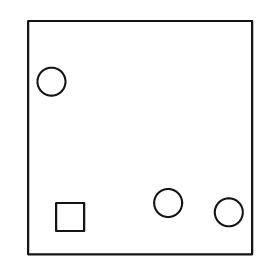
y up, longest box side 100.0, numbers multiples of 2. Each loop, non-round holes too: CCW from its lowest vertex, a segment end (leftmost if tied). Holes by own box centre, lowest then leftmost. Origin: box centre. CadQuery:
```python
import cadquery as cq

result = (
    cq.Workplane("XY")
    .moveTo(-48.0, -50.0)
    .lineTo(48.0, -50.0)
    .lineTo(48.0, 50.0)
    .lineTo(-48.0, 50.0)
    .close()
    .moveTo(-36.0, -40.0)
    .lineTo(-24.0, -40.0)
    .lineTo(-24.0, -28.0)
    .lineTo(-36.0, -28.0)
    .close()
    .moveTo(38.0, -32.0)
    .circle(6.0)
    .moveTo(12.0, -28.0)
    .circle(6.0)
    .moveTo(-38.0, 24.0)
    .circle(6.0)
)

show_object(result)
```